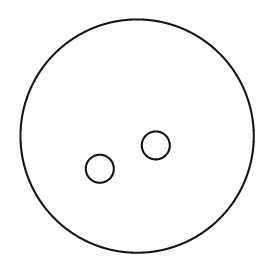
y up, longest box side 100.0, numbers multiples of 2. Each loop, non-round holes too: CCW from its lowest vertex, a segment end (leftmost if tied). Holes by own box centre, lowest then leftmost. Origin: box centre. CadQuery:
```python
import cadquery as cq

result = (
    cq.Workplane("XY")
    .moveTo(0.0, 0.0)
    .circle(50.0)
    .moveTo(-16.0, -14.0)
    .circle(6.0)
    .moveTo(8.0, -4.0)
    .circle(6.0)
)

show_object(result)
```